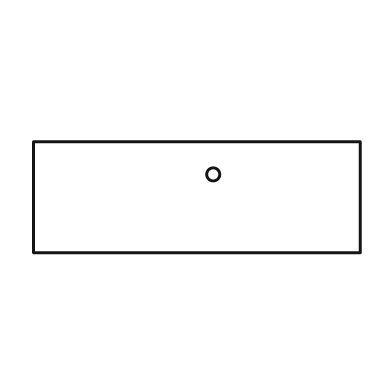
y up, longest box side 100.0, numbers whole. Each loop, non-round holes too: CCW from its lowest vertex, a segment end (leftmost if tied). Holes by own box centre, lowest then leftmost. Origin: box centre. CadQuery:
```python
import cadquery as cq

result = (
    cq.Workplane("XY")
    .moveTo(-50.0, -17.0)
    .lineTo(50.0, -17.0)
    .lineTo(50.0, 17.0)
    .lineTo(-50.0, 17.0)
    .close()
    .moveTo(5.0, 7.0)
    .circle(2.0)
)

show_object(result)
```